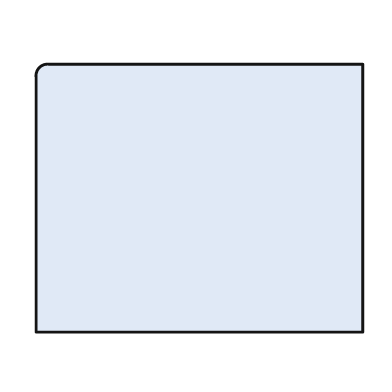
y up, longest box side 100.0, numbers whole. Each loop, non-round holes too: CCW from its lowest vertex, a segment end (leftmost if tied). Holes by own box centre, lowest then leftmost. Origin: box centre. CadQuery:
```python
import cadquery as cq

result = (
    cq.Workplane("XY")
    .moveTo(-50.0, -41.0)
    .lineTo(50.0, -41.0)
    .lineTo(50.0, 41.0)
    .lineTo(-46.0, 41.0)
    .threePointArc((-49.0, 40.0), (-50.0, 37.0))
    .close()
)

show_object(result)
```